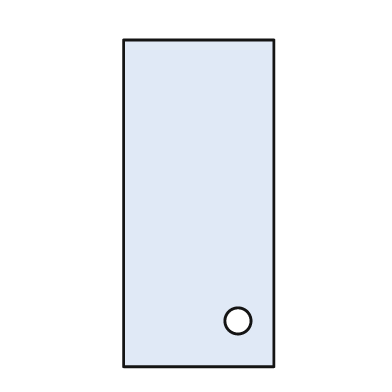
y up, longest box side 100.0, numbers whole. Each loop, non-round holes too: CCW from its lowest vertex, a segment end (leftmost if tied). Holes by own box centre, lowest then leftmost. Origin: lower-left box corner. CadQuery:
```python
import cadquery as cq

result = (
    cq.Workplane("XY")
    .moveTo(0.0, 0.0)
    .lineTo(46.0, 0.0)
    .lineTo(46.0, 100.0)
    .lineTo(0.0, 100.0)
    .close()
    .moveTo(35.0, 14.0)
    .circle(4.0)
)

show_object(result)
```